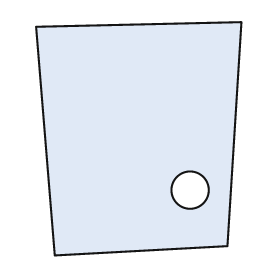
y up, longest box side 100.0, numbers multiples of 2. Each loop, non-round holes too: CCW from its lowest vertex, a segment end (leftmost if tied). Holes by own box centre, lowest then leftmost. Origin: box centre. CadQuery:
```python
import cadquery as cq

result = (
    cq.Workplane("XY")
    .moveTo(-36.0, -50.0)
    .lineTo(38.0, -46.0)
    .lineTo(44.0, 50.0)
    .lineTo(-44.0, 48.0)
    .close()
    .moveTo(22.0, -22.0)
    .circle(8.0)
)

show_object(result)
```